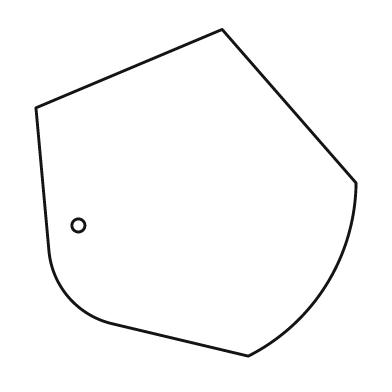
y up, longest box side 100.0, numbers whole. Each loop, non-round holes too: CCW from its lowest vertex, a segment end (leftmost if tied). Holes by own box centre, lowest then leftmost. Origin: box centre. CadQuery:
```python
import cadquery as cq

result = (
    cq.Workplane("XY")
    .moveTo(16.0, -50.0)
    .threePointArc((40.0, -28.0), (49.0, 3.0))
    .lineTo(8.0, 50.0)
    .lineTo(-49.0, 26.0)
    .lineTo(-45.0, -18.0)
    .threePointArc((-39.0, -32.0), (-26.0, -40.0))
    .close()
    .moveTo(-36.0, -10.0)
    .circle(2.0)
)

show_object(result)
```